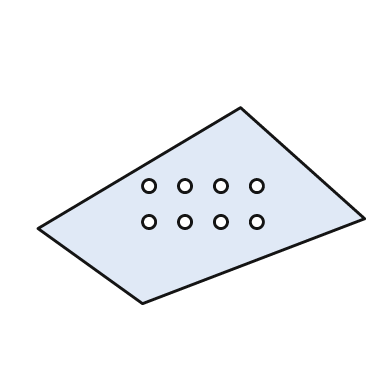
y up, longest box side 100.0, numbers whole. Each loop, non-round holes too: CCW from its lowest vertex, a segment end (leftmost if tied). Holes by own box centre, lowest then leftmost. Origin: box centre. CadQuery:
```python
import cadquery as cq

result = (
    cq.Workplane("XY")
    .moveTo(-18.0, -30.0)
    .lineTo(50.0, -4.0)
    .lineTo(12.0, 30.0)
    .lineTo(-50.0, -7.0)
    .close()
    .moveTo(-16.0, -5.0)
    .circle(2.0)
    .moveTo(-5.0, -5.0)
    .circle(2.0)
    .moveTo(6.0, -5.0)
    .circle(2.0)
    .moveTo(17.0, -5.0)
    .circle(2.0)
    .moveTo(-16.0, 6.0)
    .circle(2.0)
    .moveTo(-5.0, 6.0)
    .circle(2.0)
    .moveTo(6.0, 6.0)
    .circle(2.0)
    .moveTo(17.0, 6.0)
    .circle(2.0)
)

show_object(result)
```